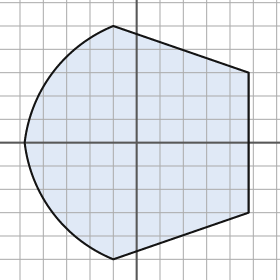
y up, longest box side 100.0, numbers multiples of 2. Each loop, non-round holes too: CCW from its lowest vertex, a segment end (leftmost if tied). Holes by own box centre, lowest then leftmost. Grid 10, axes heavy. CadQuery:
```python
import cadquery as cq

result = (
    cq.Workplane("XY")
    .moveTo(-10.0, -50.0)
    .lineTo(48.0, -30.0)
    .lineTo(48.0, 30.0)
    .lineTo(-10.0, 50.0)
    .threePointArc((-36.0, 30.0), (-48.0, 0.0))
    .threePointArc((-36.0, -30.0), (-10.0, -50.0))
    .close()
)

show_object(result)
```